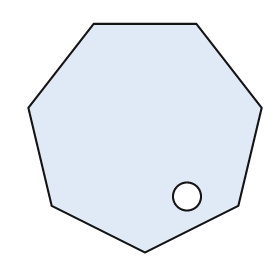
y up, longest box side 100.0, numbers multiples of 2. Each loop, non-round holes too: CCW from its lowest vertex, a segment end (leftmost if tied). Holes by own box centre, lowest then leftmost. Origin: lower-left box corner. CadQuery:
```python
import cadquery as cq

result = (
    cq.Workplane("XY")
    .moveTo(50.0, 0.0)
    .lineTo(90.0, 20.0)
    .lineTo(100.0, 62.0)
    .lineTo(72.0, 98.0)
    .lineTo(28.0, 98.0)
    .lineTo(0.0, 62.0)
    .lineTo(10.0, 20.0)
    .close()
    .moveTo(68.0, 24.0)
    .circle(6.0)
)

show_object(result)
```